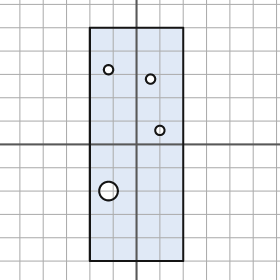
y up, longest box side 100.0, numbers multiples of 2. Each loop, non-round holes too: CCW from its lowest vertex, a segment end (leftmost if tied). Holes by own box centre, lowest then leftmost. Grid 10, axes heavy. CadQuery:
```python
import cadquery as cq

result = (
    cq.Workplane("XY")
    .moveTo(-20.0, -50.0)
    .lineTo(20.0, -50.0)
    .lineTo(20.0, 50.0)
    .lineTo(-20.0, 50.0)
    .close()
    .moveTo(-12.0, -20.0)
    .circle(4.0)
    .moveTo(10.0, 6.0)
    .circle(2.0)
    .moveTo(6.0, 28.0)
    .circle(2.0)
    .moveTo(-12.0, 32.0)
    .circle(2.0)
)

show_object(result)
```